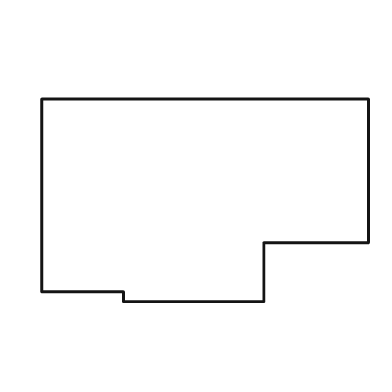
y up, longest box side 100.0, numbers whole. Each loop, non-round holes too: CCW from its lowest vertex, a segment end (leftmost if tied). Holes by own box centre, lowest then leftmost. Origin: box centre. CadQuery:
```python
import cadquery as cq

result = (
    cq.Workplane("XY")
    .moveTo(-25.0, -31.0)
    .lineTo(18.0, -31.0)
    .lineTo(18.0, -13.0)
    .lineTo(50.0, -13.0)
    .lineTo(50.0, 31.0)
    .lineTo(-50.0, 31.0)
    .lineTo(-50.0, -28.0)
    .lineTo(-25.0, -28.0)
    .close()
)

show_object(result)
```